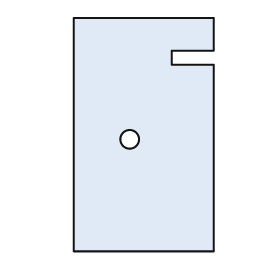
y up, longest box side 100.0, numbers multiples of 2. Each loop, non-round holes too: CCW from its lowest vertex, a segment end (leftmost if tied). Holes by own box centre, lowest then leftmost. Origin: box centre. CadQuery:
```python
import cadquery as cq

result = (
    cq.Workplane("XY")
    .moveTo(-30.0, -50.0)
    .lineTo(30.0, -50.0)
    .lineTo(30.0, 30.0)
    .lineTo(12.0, 30.0)
    .lineTo(12.0, 36.0)
    .lineTo(30.0, 36.0)
    .lineTo(30.0, 50.0)
    .lineTo(-30.0, 50.0)
    .close()
    .moveTo(-6.0, -2.0)
    .circle(4.0)
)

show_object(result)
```